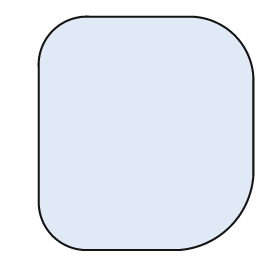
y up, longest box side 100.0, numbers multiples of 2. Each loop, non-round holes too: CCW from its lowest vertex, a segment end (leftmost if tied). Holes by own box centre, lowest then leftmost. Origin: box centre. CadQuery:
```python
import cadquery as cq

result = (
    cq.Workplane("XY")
    .moveTo(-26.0, -50.0)
    .lineTo(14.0, -50.0)
    .threePointArc((36.0, -40.0), (46.0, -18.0))
    .lineTo(46.0, 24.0)
    .threePointArc((38.0, 42.0), (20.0, 50.0))
    .lineTo(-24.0, 50.0)
    .threePointArc((-40.0, 44.0), (-46.0, 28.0))
    .lineTo(-46.0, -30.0)
    .threePointArc((-40.0, -44.0), (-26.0, -50.0))
    .close()
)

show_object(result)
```